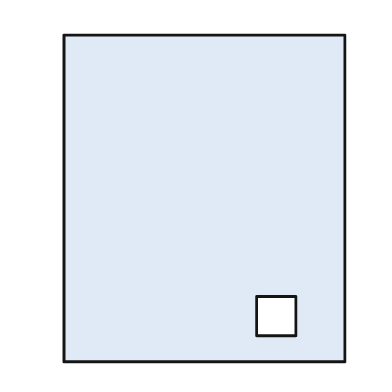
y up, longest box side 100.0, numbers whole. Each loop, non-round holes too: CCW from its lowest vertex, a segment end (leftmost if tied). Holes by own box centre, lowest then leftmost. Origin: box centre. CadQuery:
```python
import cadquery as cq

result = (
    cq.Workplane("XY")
    .moveTo(-43.0, -50.0)
    .lineTo(43.0, -50.0)
    .lineTo(43.0, 50.0)
    .lineTo(-43.0, 50.0)
    .close()
    .moveTo(16.0, -42.0)
    .lineTo(28.0, -42.0)
    .lineTo(28.0, -30.0)
    .lineTo(16.0, -30.0)
    .close()
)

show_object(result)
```